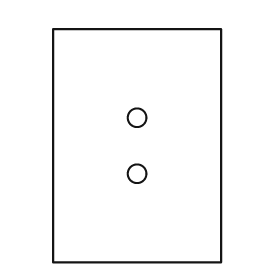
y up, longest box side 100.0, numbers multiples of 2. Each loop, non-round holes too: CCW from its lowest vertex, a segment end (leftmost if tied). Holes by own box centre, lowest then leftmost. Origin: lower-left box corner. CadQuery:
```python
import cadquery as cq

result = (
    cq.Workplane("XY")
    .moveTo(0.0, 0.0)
    .lineTo(72.0, 0.0)
    .lineTo(72.0, 100.0)
    .lineTo(0.0, 100.0)
    .close()
    .moveTo(36.0, 38.0)
    .circle(4.0)
    .moveTo(36.0, 62.0)
    .circle(4.0)
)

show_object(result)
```